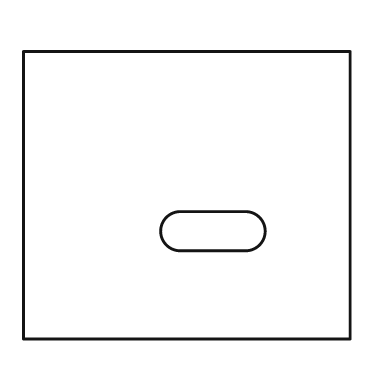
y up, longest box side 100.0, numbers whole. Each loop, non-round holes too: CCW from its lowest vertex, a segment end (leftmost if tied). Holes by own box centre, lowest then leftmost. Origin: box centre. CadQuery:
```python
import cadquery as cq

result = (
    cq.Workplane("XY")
    .moveTo(-50.0, -44.0)
    .lineTo(50.0, -44.0)
    .lineTo(50.0, 44.0)
    .lineTo(-50.0, 44.0)
    .close()
    .moveTo(-2.0, -17.0)
    .lineTo(18.0, -17.0)
    .threePointArc((24.0, -11.0), (18.0, -5.0))
    .lineTo(-2.0, -5.0)
    .threePointArc((-8.0, -11.0), (-2.0, -17.0))
    .close()
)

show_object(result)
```